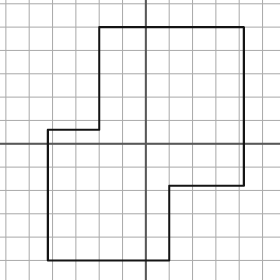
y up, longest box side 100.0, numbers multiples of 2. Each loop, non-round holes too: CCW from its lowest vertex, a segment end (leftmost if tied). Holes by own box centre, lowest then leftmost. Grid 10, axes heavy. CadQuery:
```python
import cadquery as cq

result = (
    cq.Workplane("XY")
    .moveTo(-42.0, -50.0)
    .lineTo(10.0, -50.0)
    .lineTo(10.0, -18.0)
    .lineTo(42.0, -18.0)
    .lineTo(42.0, 50.0)
    .lineTo(-20.0, 50.0)
    .lineTo(-20.0, 6.0)
    .lineTo(-42.0, 6.0)
    .close()
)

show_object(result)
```